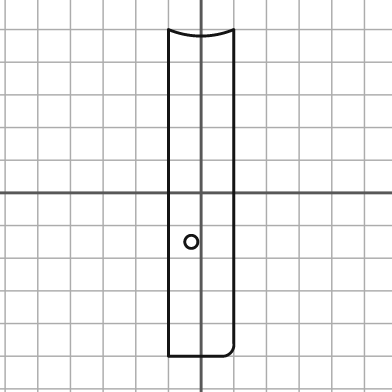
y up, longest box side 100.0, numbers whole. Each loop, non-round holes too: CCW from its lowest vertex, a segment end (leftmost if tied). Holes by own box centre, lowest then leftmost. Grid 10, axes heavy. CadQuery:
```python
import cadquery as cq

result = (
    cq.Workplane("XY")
    .moveTo(-10.0, -50.0)
    .lineTo(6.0, -50.0)
    .threePointArc((9.0, -49.0), (10.0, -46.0))
    .lineTo(10.0, 50.0)
    .threePointArc((0.0, 48.0), (-10.0, 50.0))
    .close()
    .moveTo(-3.0, -15.0)
    .circle(2.0)
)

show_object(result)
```